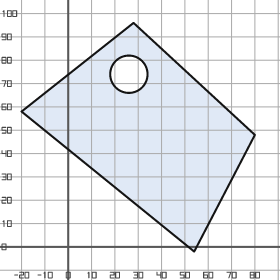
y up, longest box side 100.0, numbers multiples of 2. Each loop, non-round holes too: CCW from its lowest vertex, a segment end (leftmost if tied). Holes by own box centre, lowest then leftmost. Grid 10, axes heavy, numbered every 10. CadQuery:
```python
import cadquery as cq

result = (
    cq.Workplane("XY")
    .moveTo(54.0, -2.0)
    .lineTo(80.0, 48.0)
    .lineTo(28.0, 96.0)
    .lineTo(-20.0, 58.0)
    .close()
    .moveTo(26.0, 74.0)
    .circle(8.0)
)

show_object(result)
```